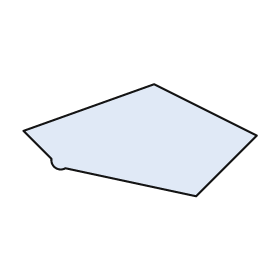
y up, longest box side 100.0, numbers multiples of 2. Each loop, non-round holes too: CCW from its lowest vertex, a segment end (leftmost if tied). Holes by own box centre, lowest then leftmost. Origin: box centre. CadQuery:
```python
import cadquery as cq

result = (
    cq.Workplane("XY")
    .moveTo(24.0, -24.0)
    .lineTo(50.0, 2.0)
    .lineTo(6.0, 24.0)
    .lineTo(-50.0, 4.0)
    .lineTo(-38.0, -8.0)
    .threePointArc((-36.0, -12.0), (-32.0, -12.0))
    .close()
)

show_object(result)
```